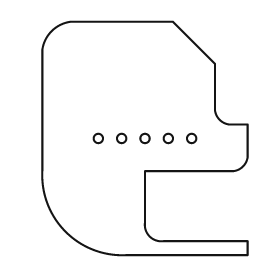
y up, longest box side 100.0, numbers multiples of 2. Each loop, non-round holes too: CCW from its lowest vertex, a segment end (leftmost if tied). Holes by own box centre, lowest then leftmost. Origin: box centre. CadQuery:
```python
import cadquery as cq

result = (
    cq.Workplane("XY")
    .moveTo(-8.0, -50.0)
    .lineTo(44.0, -50.0)
    .lineTo(44.0, -44.0)
    .lineTo(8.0, -44.0)
    .threePointArc((2.0, -42.0), (0.0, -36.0))
    .lineTo(0.0, -14.0)
    .lineTo(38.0, -14.0)
    .threePointArc((42.0, -12.0), (44.0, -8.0))
    .lineTo(44.0, 6.0)
    .lineTo(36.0, 6.0)
    .threePointArc((32.0, 8.0), (30.0, 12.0))
    .lineTo(30.0, 32.0)
    .lineTo(12.0, 50.0)
    .lineTo(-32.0, 50.0)
    .threePointArc((-40.0, 46.0), (-44.0, 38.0))
    .lineTo(-44.0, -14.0)
    .threePointArc((-34.0, -40.0), (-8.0, -50.0))
    .close()
    .moveTo(-20.0, 0.0)
    .circle(2.0)
    .moveTo(-10.0, 0.0)
    .circle(2.0)
    .moveTo(0.0, 0.0)
    .circle(2.0)
    .moveTo(10.0, 0.0)
    .circle(2.0)
    .moveTo(20.0, 0.0)
    .circle(2.0)
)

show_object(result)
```